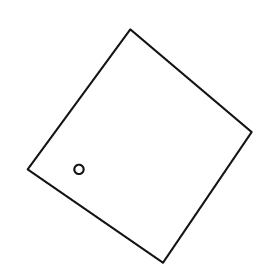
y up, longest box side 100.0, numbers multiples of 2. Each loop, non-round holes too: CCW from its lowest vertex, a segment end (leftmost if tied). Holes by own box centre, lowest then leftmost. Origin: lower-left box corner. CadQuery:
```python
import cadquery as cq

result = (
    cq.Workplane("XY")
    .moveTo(58.0, 0.0)
    .lineTo(96.0, 56.0)
    .lineTo(44.0, 100.0)
    .lineTo(0.0, 40.0)
    .close()
    .moveTo(22.0, 40.0)
    .circle(2.0)
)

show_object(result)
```